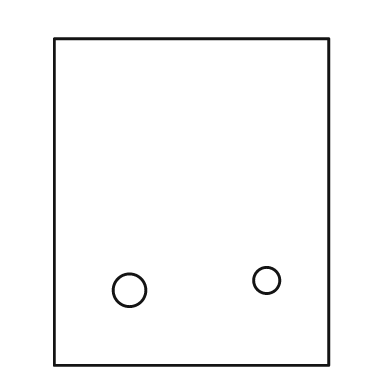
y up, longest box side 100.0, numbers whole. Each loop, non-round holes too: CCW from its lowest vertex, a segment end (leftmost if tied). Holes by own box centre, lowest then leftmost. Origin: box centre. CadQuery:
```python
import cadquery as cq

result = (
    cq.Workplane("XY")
    .moveTo(-42.0, -50.0)
    .lineTo(42.0, -50.0)
    .lineTo(42.0, 50.0)
    .lineTo(-42.0, 50.0)
    .close()
    .moveTo(-19.0, -27.0)
    .circle(5.0)
    .moveTo(23.0, -24.0)
    .circle(4.0)
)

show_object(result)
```